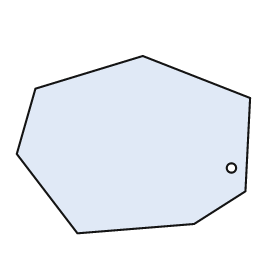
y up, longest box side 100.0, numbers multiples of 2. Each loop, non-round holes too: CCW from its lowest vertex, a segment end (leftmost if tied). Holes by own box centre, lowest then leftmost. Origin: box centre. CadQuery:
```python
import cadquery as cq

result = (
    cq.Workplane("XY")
    .moveTo(-24.0, -38.0)
    .lineTo(26.0, -34.0)
    .lineTo(48.0, -20.0)
    .lineTo(50.0, 20.0)
    .lineTo(4.0, 38.0)
    .lineTo(-42.0, 24.0)
    .lineTo(-50.0, -4.0)
    .close()
    .moveTo(42.0, -10.0)
    .circle(2.0)
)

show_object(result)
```